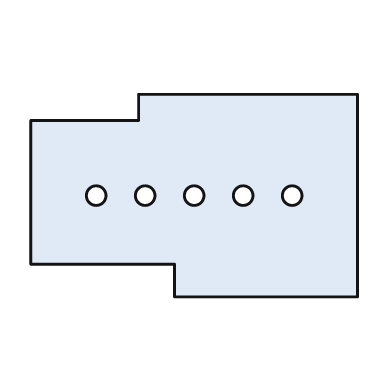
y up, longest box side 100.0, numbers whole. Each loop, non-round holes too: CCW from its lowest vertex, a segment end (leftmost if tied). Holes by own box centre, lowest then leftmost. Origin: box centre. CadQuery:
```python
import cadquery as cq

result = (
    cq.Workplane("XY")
    .moveTo(-6.0, -31.0)
    .lineTo(50.0, -31.0)
    .lineTo(50.0, 31.0)
    .lineTo(-17.0, 31.0)
    .lineTo(-17.0, 23.0)
    .lineTo(-50.0, 23.0)
    .lineTo(-50.0, -21.0)
    .lineTo(-6.0, -21.0)
    .close()
    .moveTo(-30.0, 0.0)
    .circle(3.0)
    .moveTo(-15.0, 0.0)
    .circle(3.0)
    .moveTo(0.0, 0.0)
    .circle(3.0)
    .moveTo(15.0, 0.0)
    .circle(3.0)
    .moveTo(30.0, 0.0)
    .circle(3.0)
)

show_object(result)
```